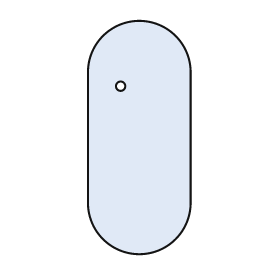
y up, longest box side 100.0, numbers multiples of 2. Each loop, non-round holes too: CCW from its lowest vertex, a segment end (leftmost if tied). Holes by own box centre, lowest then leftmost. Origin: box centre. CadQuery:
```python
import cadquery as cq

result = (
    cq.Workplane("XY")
    .moveTo(-22.0, -28.0)
    .threePointArc((0.0, -50.0), (22.0, -28.0))
    .lineTo(22.0, 28.0)
    .threePointArc((0.0, 50.0), (-22.0, 28.0))
    .close()
    .moveTo(-8.0, 22.0)
    .circle(2.0)
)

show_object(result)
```